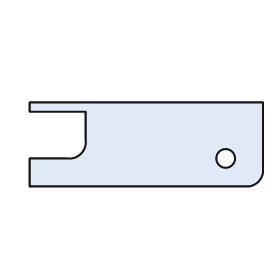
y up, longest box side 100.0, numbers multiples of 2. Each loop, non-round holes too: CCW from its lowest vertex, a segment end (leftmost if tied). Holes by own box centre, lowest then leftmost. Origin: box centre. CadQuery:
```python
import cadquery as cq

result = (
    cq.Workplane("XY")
    .moveTo(-50.0, -18.0)
    .lineTo(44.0, -18.0)
    .threePointArc((48.0, -16.0), (50.0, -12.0))
    .lineTo(50.0, 18.0)
    .lineTo(-50.0, 18.0)
    .lineTo(-50.0, 14.0)
    .lineTo(-26.0, 14.0)
    .lineTo(-26.0, 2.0)
    .threePointArc((-28.0, -4.0), (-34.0, -6.0))
    .lineTo(-50.0, -6.0)
    .close()
    .moveTo(34.0, -6.0)
    .circle(4.0)
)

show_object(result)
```